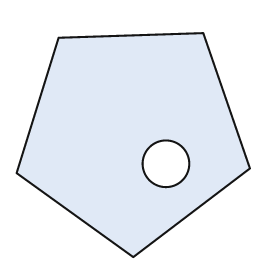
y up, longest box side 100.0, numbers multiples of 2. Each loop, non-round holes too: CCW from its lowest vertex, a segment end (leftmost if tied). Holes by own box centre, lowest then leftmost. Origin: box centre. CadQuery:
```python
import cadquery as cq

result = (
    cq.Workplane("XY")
    .moveTo(0.0, -48.0)
    .lineTo(50.0, -10.0)
    .lineTo(30.0, 48.0)
    .lineTo(-32.0, 46.0)
    .lineTo(-50.0, -12.0)
    .close()
    .moveTo(14.0, -8.0)
    .circle(10.0)
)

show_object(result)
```